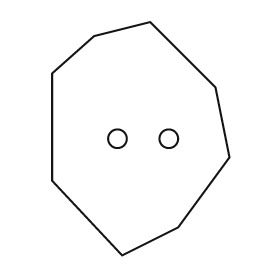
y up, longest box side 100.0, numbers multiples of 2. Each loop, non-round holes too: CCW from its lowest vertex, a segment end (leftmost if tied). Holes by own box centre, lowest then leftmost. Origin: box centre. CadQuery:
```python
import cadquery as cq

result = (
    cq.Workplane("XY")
    .moveTo(-8.0, -50.0)
    .lineTo(16.0, -38.0)
    .lineTo(38.0, -8.0)
    .lineTo(32.0, 22.0)
    .lineTo(4.0, 50.0)
    .lineTo(-20.0, 44.0)
    .lineTo(-38.0, 28.0)
    .lineTo(-38.0, -18.0)
    .close()
    .moveTo(-10.0, 0.0)
    .circle(4.0)
    .moveTo(12.0, 0.0)
    .circle(4.0)
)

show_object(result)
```